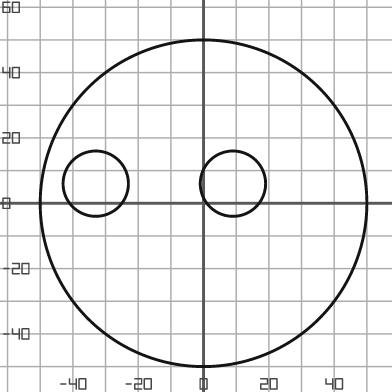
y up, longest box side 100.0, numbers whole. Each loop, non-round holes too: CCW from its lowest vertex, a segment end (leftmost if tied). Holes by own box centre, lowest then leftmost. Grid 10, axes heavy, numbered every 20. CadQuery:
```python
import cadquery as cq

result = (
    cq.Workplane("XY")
    .moveTo(0.0, 0.0)
    .circle(50.0)
    .moveTo(-33.0, 6.0)
    .circle(10.0)
    .moveTo(9.0, 6.0)
    .circle(10.0)
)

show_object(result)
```